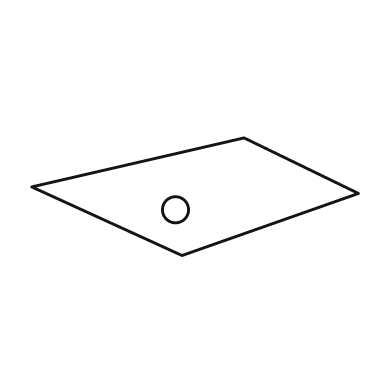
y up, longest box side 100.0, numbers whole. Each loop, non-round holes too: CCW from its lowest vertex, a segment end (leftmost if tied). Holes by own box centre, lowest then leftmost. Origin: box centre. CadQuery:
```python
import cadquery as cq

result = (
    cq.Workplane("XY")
    .moveTo(-4.0, -18.0)
    .lineTo(50.0, 1.0)
    .lineTo(15.0, 18.0)
    .lineTo(-50.0, 3.0)
    .close()
    .moveTo(-6.0, -4.0)
    .circle(4.0)
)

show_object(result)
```